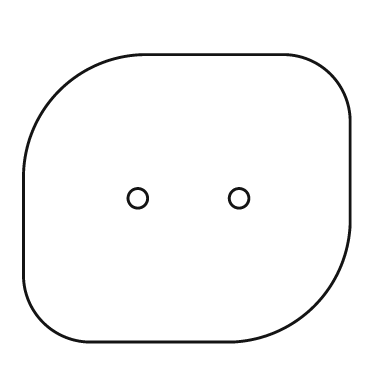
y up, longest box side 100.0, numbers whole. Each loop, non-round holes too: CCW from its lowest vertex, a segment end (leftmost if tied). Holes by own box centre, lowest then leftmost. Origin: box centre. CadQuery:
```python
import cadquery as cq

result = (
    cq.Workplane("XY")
    .moveTo(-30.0, -44.0)
    .lineTo(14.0, -44.0)
    .threePointArc((39.0, -33.0), (50.0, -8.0))
    .lineTo(50.0, 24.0)
    .threePointArc((44.0, 38.0), (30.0, 44.0))
    .lineTo(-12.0, 44.0)
    .threePointArc((-39.0, 33.0), (-50.0, 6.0))
    .lineTo(-50.0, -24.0)
    .threePointArc((-44.0, -38.0), (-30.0, -44.0))
    .close()
    .moveTo(-15.0, 0.0)
    .circle(3.0)
    .moveTo(16.0, 0.0)
    .circle(3.0)
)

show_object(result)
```